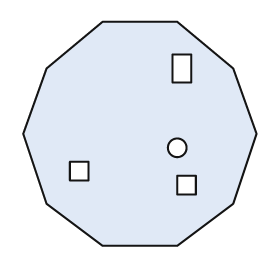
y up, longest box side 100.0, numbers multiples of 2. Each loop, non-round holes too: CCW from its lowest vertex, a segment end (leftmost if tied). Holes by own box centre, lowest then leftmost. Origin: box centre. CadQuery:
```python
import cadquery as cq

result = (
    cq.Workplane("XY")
    .moveTo(-16.0, -48.0)
    .lineTo(16.0, -48.0)
    .lineTo(40.0, -30.0)
    .lineTo(50.0, 0.0)
    .lineTo(40.0, 28.0)
    .lineTo(16.0, 48.0)
    .lineTo(-16.0, 48.0)
    .lineTo(-40.0, 28.0)
    .lineTo(-50.0, 0.0)
    .lineTo(-40.0, -30.0)
    .close()
    .moveTo(16.0, -26.0)
    .lineTo(24.0, -26.0)
    .lineTo(24.0, -18.0)
    .lineTo(16.0, -18.0)
    .close()
    .moveTo(-30.0, -20.0)
    .lineTo(-22.0, -20.0)
    .lineTo(-22.0, -12.0)
    .lineTo(-30.0, -12.0)
    .close()
    .moveTo(16.0, -6.0)
    .circle(4.0)
    .moveTo(14.0, 22.0)
    .lineTo(22.0, 22.0)
    .lineTo(22.0, 34.0)
    .lineTo(14.0, 34.0)
    .close()
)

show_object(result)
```